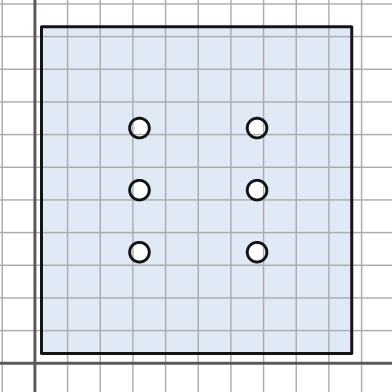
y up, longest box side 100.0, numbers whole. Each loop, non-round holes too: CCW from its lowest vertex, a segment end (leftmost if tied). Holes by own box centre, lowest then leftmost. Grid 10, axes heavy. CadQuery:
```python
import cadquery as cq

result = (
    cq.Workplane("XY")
    .moveTo(2.0, 3.0)
    .lineTo(97.0, 3.0)
    .lineTo(97.0, 103.0)
    .lineTo(2.0, 103.0)
    .close()
    .moveTo(32.0, 34.0)
    .circle(3.0)
    .moveTo(68.0, 34.0)
    .circle(3.0)
    .moveTo(32.0, 53.0)
    .circle(3.0)
    .moveTo(68.0, 53.0)
    .circle(3.0)
    .moveTo(32.0, 72.0)
    .circle(3.0)
    .moveTo(68.0, 72.0)
    .circle(3.0)
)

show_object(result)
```